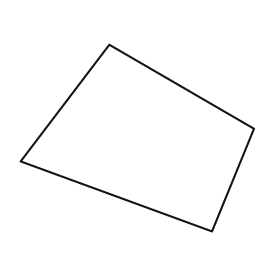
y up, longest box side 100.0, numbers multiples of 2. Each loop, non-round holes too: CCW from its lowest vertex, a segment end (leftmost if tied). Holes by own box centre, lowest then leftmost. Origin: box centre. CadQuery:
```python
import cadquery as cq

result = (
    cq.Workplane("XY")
    .moveTo(32.0, -40.0)
    .lineTo(50.0, 4.0)
    .lineTo(-12.0, 40.0)
    .lineTo(-50.0, -10.0)
    .close()
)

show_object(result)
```